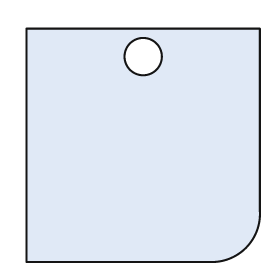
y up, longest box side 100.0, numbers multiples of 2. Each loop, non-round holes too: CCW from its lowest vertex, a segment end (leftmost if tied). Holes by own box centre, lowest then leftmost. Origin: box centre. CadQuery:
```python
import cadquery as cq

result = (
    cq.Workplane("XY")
    .moveTo(-50.0, -50.0)
    .lineTo(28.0, -50.0)
    .threePointArc((44.0, -44.0), (50.0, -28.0))
    .lineTo(50.0, 50.0)
    .lineTo(-50.0, 50.0)
    .close()
    .moveTo(0.0, 38.0)
    .circle(8.0)
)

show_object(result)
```